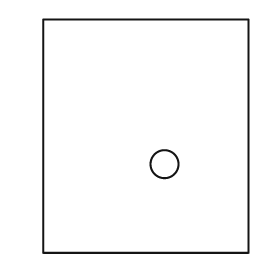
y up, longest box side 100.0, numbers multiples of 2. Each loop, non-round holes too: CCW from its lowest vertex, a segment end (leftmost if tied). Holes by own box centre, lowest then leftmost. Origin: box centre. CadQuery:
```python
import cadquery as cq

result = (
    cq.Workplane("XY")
    .moveTo(-44.0, -50.0)
    .lineTo(44.0, -50.0)
    .lineTo(44.0, 50.0)
    .lineTo(-44.0, 50.0)
    .close()
    .moveTo(8.0, -12.0)
    .circle(6.0)
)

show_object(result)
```